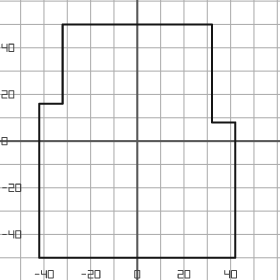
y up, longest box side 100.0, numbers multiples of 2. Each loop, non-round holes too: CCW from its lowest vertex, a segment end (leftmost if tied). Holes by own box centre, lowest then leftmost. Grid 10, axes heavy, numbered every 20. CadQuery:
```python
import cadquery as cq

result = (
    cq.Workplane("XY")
    .moveTo(-42.0, -50.0)
    .lineTo(42.0, -50.0)
    .lineTo(42.0, 8.0)
    .lineTo(32.0, 8.0)
    .lineTo(32.0, 50.0)
    .lineTo(-32.0, 50.0)
    .lineTo(-32.0, 16.0)
    .lineTo(-42.0, 16.0)
    .close()
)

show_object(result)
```